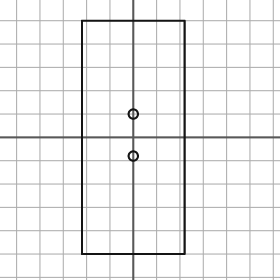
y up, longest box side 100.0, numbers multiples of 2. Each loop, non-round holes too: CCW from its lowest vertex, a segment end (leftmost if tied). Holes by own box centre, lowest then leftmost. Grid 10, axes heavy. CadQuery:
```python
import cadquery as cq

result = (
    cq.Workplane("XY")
    .moveTo(-22.0, -50.0)
    .lineTo(22.0, -50.0)
    .lineTo(22.0, 50.0)
    .lineTo(-22.0, 50.0)
    .close()
    .moveTo(0.0, -8.0)
    .circle(2.0)
    .moveTo(0.0, 10.0)
    .circle(2.0)
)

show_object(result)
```